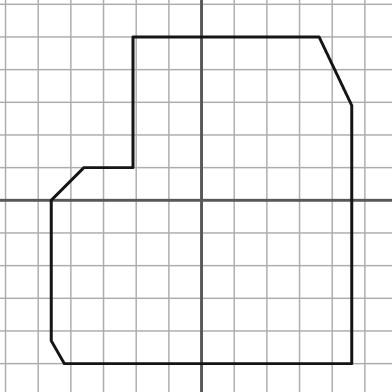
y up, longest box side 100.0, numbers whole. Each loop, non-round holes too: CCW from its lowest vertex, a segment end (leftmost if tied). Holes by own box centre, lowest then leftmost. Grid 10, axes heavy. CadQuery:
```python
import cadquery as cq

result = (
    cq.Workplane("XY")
    .moveTo(-42.0, -50.0)
    .lineTo(46.0, -50.0)
    .lineTo(46.0, 29.0)
    .lineTo(36.0, 50.0)
    .lineTo(-21.0, 50.0)
    .lineTo(-21.0, 10.0)
    .lineTo(-36.0, 10.0)
    .lineTo(-46.0, 0.0)
    .lineTo(-46.0, -43.0)
    .close()
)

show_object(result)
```